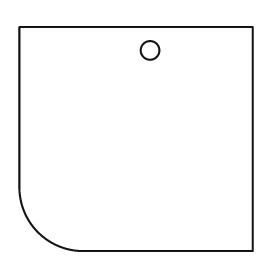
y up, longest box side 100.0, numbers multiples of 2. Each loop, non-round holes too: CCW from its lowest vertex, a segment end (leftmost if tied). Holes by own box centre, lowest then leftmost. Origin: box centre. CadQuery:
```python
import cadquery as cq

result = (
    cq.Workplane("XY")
    .moveTo(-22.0, -48.0)
    .lineTo(50.0, -48.0)
    .lineTo(50.0, 48.0)
    .lineTo(-50.0, 48.0)
    .lineTo(-50.0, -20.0)
    .threePointArc((-42.0, -40.0), (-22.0, -48.0))
    .close()
    .moveTo(6.0, 38.0)
    .circle(4.0)
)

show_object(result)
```